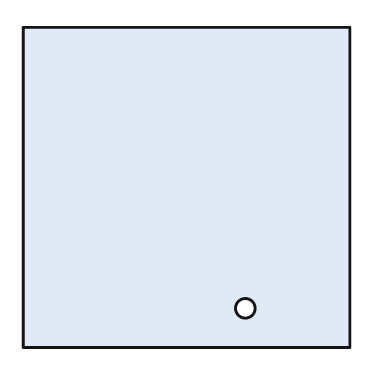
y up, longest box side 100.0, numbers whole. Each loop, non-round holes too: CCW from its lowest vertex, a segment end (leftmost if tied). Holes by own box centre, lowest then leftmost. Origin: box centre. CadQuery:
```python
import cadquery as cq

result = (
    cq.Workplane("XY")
    .moveTo(-50.0, -49.0)
    .lineTo(50.0, -49.0)
    .lineTo(50.0, 49.0)
    .lineTo(-50.0, 49.0)
    .close()
    .moveTo(18.0, -37.0)
    .circle(3.0)
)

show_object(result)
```